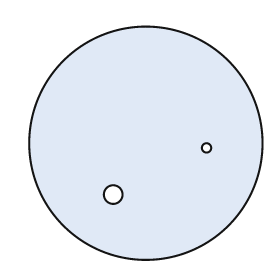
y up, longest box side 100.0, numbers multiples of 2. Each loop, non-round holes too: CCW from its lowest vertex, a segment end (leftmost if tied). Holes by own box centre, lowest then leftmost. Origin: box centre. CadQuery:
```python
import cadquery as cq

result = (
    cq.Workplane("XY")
    .moveTo(0.0, 0.0)
    .circle(50.0)
    .moveTo(-14.0, -22.0)
    .circle(4.0)
    .moveTo(26.0, -2.0)
    .circle(2.0)
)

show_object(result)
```